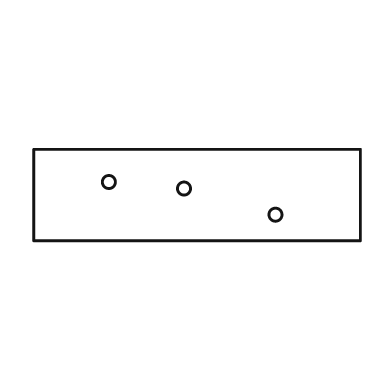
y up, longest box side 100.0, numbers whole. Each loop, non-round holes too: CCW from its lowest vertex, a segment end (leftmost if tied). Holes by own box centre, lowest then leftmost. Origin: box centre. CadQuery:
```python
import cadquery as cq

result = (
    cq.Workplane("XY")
    .moveTo(-50.0, -14.0)
    .lineTo(50.0, -14.0)
    .lineTo(50.0, 14.0)
    .lineTo(-50.0, 14.0)
    .close()
    .moveTo(24.0, -6.0)
    .circle(2.0)
    .moveTo(-4.0, 2.0)
    .circle(2.0)
    .moveTo(-27.0, 4.0)
    .circle(2.0)
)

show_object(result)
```